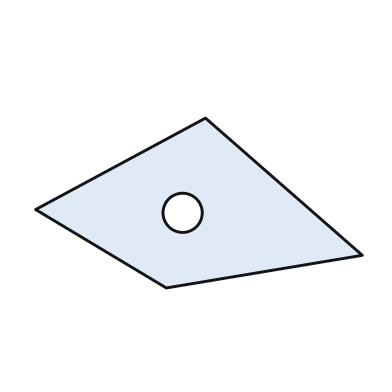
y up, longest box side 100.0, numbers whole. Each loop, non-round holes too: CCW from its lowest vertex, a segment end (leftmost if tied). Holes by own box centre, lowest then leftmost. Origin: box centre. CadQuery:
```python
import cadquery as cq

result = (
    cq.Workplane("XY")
    .moveTo(-10.0, -26.0)
    .lineTo(50.0, -16.0)
    .lineTo(2.0, 26.0)
    .lineTo(-50.0, -2.0)
    .close()
    .moveTo(-5.0, -3.0)
    .circle(6.0)
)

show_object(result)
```